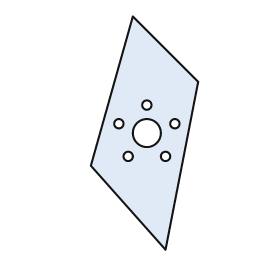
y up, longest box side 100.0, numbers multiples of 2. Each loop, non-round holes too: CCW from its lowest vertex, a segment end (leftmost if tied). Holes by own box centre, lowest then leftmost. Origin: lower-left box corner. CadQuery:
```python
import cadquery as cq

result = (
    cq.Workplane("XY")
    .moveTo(32.0, 0.0)
    .lineTo(46.0, 72.0)
    .lineTo(18.0, 100.0)
    .lineTo(0.0, 36.0)
    .close()
    .moveTo(16.0, 40.0)
    .circle(2.0)
    .moveTo(32.0, 40.0)
    .circle(2.0)
    .moveTo(24.0, 50.0)
    .circle(6.0)
    .moveTo(12.0, 54.0)
    .circle(2.0)
    .moveTo(36.0, 54.0)
    .circle(2.0)
    .moveTo(24.0, 62.0)
    .circle(2.0)
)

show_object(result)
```